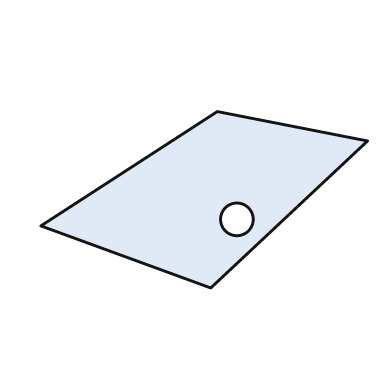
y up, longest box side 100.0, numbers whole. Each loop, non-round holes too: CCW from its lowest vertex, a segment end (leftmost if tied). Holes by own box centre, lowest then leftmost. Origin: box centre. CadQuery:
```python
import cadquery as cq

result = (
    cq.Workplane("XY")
    .moveTo(2.0, -27.0)
    .lineTo(50.0, 18.0)
    .lineTo(4.0, 27.0)
    .lineTo(-50.0, -8.0)
    .close()
    .moveTo(10.0, -6.0)
    .circle(5.0)
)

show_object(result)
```